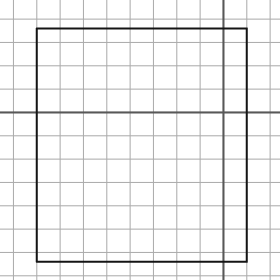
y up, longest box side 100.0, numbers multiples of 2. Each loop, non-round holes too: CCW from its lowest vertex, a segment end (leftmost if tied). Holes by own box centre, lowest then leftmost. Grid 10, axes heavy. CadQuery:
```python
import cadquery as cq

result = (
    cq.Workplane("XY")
    .moveTo(-80.0, -64.0)
    .lineTo(10.0, -64.0)
    .lineTo(10.0, 36.0)
    .lineTo(-80.0, 36.0)
    .close()
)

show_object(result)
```